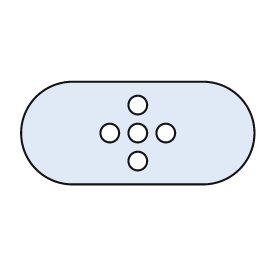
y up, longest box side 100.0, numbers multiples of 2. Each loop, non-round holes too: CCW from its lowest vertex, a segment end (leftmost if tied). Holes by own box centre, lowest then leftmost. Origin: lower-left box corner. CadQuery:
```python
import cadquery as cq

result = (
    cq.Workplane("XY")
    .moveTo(22.0, 0.0)
    .lineTo(78.0, 0.0)
    .threePointArc((100.0, 22.0), (78.0, 44.0))
    .lineTo(22.0, 44.0)
    .threePointArc((0.0, 22.0), (22.0, 0.0))
    .close()
    .moveTo(50.0, 10.0)
    .circle(4.0)
    .moveTo(38.0, 22.0)
    .circle(4.0)
    .moveTo(50.0, 22.0)
    .circle(4.0)
    .moveTo(62.0, 22.0)
    .circle(4.0)
    .moveTo(50.0, 34.0)
    .circle(4.0)
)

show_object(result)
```